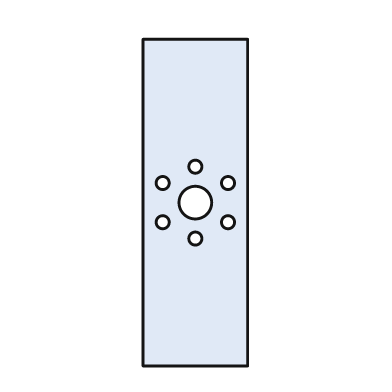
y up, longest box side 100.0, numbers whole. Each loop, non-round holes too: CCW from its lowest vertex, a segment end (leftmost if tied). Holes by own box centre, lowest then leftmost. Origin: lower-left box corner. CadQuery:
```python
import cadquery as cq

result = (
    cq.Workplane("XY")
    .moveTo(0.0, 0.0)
    .lineTo(32.0, 0.0)
    .lineTo(32.0, 100.0)
    .lineTo(0.0, 100.0)
    .close()
    .moveTo(16.0, 39.0)
    .circle(2.0)
    .moveTo(6.0, 44.0)
    .circle(2.0)
    .moveTo(26.0, 44.0)
    .circle(2.0)
    .moveTo(16.0, 50.0)
    .circle(5.0)
    .moveTo(6.0, 56.0)
    .circle(2.0)
    .moveTo(26.0, 56.0)
    .circle(2.0)
    .moveTo(16.0, 61.0)
    .circle(2.0)
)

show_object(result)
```